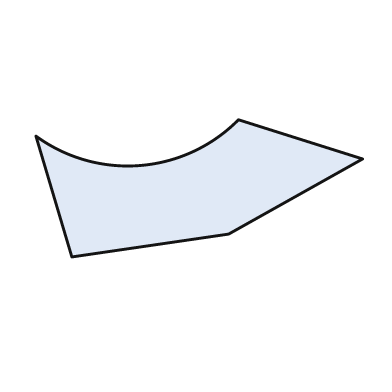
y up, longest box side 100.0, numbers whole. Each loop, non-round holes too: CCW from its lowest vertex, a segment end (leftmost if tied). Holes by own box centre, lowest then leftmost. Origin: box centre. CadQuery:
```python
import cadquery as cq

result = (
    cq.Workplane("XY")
    .moveTo(-39.0, -21.0)
    .lineTo(9.0, -14.0)
    .lineTo(50.0, 9.0)
    .lineTo(12.0, 21.0)
    .threePointArc((-18.0, 7.0), (-50.0, 16.0))
    .close()
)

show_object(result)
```